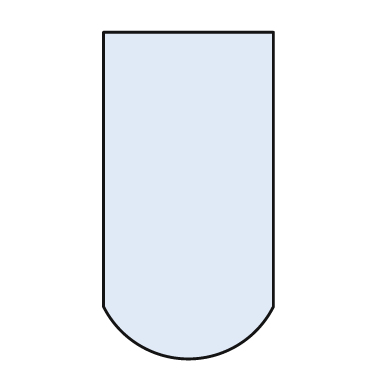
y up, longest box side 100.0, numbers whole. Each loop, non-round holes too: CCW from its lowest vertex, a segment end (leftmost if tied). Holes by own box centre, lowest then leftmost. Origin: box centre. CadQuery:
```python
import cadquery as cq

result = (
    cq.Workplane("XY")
    .moveTo(-26.0, -34.0)
    .threePointArc((0.0, -50.0), (26.0, -34.0))
    .lineTo(26.0, 50.0)
    .lineTo(-26.0, 50.0)
    .close()
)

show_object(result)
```